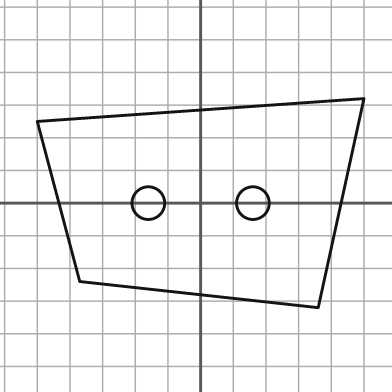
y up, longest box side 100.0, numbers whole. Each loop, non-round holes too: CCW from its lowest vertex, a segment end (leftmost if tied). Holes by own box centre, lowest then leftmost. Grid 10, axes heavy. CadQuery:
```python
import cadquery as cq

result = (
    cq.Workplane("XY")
    .moveTo(36.0, -32.0)
    .lineTo(50.0, 32.0)
    .lineTo(-50.0, 25.0)
    .lineTo(-37.0, -24.0)
    .close()
    .moveTo(-16.0, 0.0)
    .circle(5.0)
    .moveTo(16.0, 0.0)
    .circle(5.0)
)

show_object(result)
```